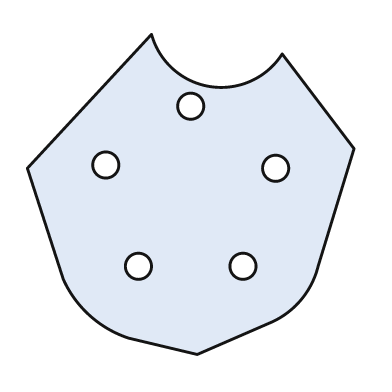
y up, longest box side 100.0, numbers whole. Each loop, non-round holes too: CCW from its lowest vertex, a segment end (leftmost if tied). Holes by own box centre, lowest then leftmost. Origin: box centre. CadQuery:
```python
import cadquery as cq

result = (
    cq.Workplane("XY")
    .moveTo(2.0, -49.0)
    .lineTo(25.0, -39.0)
    .threePointArc((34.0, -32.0), (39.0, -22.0))
    .lineTo(50.0, 14.0)
    .lineTo(28.0, 43.0)
    .threePointArc((6.0, 33.0), (-12.0, 49.0))
    .lineTo(-50.0, 8.0)
    .lineTo(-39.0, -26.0)
    .threePointArc((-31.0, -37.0), (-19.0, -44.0))
    .close()
    .moveTo(-16.0, -22.0)
    .circle(4.0)
    .moveTo(16.0, -22.0)
    .circle(4.0)
    .moveTo(26.0, 8.0)
    .circle(4.0)
    .moveTo(-26.0, 9.0)
    .circle(4.0)
    .moveTo(0.0, 27.0)
    .circle(4.0)
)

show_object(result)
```